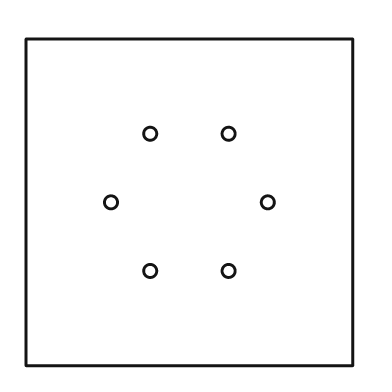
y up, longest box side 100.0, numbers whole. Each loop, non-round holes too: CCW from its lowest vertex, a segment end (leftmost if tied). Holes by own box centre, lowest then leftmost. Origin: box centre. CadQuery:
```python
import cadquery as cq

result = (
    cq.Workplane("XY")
    .moveTo(-50.0, -50.0)
    .lineTo(50.0, -50.0)
    .lineTo(50.0, 50.0)
    .lineTo(-50.0, 50.0)
    .close()
    .moveTo(-12.0, -21.0)
    .circle(2.0)
    .moveTo(12.0, -21.0)
    .circle(2.0)
    .moveTo(-24.0, 0.0)
    .circle(2.0)
    .moveTo(24.0, 0.0)
    .circle(2.0)
    .moveTo(-12.0, 21.0)
    .circle(2.0)
    .moveTo(12.0, 21.0)
    .circle(2.0)
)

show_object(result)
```